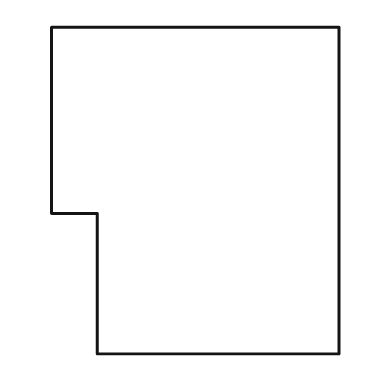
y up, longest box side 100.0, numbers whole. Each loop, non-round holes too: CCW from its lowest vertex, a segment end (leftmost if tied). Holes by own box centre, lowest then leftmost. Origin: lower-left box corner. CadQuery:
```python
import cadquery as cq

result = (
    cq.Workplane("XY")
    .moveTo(14.0, 0.0)
    .lineTo(88.0, 0.0)
    .lineTo(88.0, 100.0)
    .lineTo(0.0, 100.0)
    .lineTo(0.0, 43.0)
    .lineTo(14.0, 43.0)
    .close()
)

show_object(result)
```